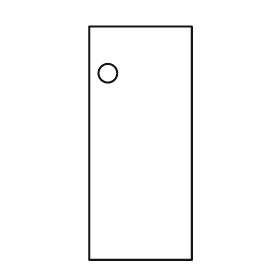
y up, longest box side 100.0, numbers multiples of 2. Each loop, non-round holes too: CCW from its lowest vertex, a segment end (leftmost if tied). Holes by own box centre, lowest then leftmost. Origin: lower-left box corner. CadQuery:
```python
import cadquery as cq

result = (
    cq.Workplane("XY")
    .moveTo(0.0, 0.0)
    .lineTo(44.0, 0.0)
    .lineTo(44.0, 100.0)
    .lineTo(0.0, 100.0)
    .close()
    .moveTo(8.0, 80.0)
    .circle(4.0)
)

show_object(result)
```